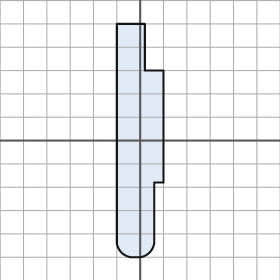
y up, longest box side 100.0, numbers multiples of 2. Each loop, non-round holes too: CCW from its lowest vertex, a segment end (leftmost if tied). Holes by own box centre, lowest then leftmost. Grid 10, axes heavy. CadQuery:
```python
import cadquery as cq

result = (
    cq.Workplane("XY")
    .moveTo(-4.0, -50.0)
    .lineTo(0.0, -50.0)
    .threePointArc((4.0, -48.0), (6.0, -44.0))
    .lineTo(6.0, -18.0)
    .lineTo(10.0, -18.0)
    .lineTo(10.0, 30.0)
    .lineTo(2.0, 30.0)
    .lineTo(2.0, 50.0)
    .lineTo(-10.0, 50.0)
    .lineTo(-10.0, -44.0)
    .threePointArc((-8.0, -48.0), (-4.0, -50.0))
    .close()
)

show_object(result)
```